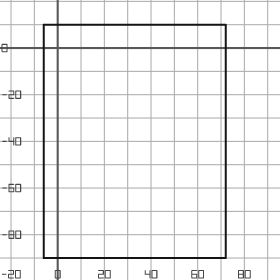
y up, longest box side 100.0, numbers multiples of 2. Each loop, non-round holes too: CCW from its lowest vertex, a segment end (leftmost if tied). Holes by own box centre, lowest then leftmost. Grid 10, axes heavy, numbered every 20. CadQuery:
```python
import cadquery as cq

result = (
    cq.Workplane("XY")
    .moveTo(-6.0, -90.0)
    .lineTo(72.0, -90.0)
    .lineTo(72.0, 10.0)
    .lineTo(-6.0, 10.0)
    .close()
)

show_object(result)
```